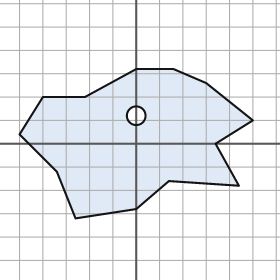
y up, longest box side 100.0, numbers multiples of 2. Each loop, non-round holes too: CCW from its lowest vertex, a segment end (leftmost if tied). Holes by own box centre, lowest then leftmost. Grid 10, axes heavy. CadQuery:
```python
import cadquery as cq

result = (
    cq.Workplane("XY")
    .moveTo(-26.0, -32.0)
    .lineTo(0.0, -28.0)
    .lineTo(14.0, -16.0)
    .lineTo(44.0, -18.0)
    .lineTo(34.0, 0.0)
    .lineTo(50.0, 10.0)
    .lineTo(30.0, 26.0)
    .lineTo(16.0, 32.0)
    .lineTo(0.0, 32.0)
    .lineTo(-22.0, 20.0)
    .lineTo(-40.0, 20.0)
    .lineTo(-50.0, 4.0)
    .lineTo(-34.0, -12.0)
    .close()
    .moveTo(0.0, 12.0)
    .circle(4.0)
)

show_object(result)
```